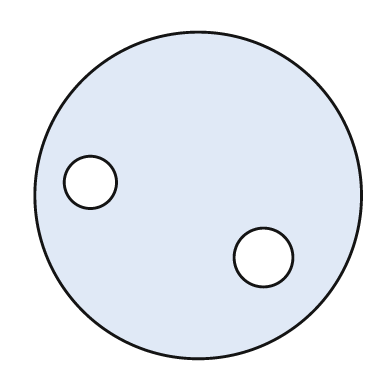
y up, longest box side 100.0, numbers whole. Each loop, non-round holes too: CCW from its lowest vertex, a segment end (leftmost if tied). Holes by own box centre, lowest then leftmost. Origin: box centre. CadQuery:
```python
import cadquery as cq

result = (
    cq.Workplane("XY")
    .moveTo(0.0, 0.0)
    .circle(50.0)
    .moveTo(20.0, -19.0)
    .circle(9.0)
    .moveTo(-33.0, 4.0)
    .circle(8.0)
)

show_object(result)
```